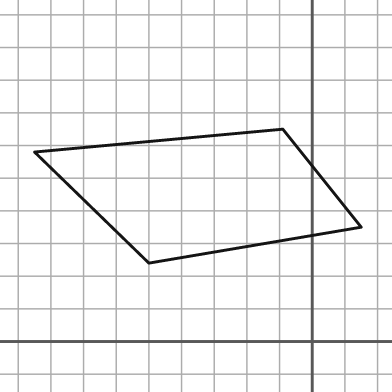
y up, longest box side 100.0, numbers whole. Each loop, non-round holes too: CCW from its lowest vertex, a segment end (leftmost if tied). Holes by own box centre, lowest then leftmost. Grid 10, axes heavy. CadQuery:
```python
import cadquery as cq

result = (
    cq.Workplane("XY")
    .moveTo(-50.0, 24.0)
    .lineTo(15.0, 35.0)
    .lineTo(-9.0, 65.0)
    .lineTo(-85.0, 58.0)
    .close()
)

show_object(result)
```